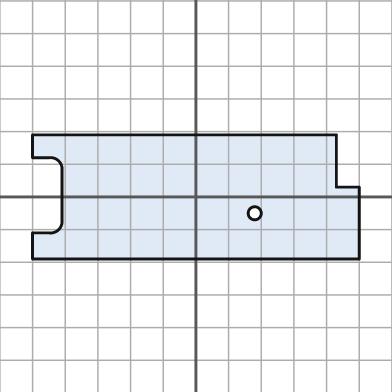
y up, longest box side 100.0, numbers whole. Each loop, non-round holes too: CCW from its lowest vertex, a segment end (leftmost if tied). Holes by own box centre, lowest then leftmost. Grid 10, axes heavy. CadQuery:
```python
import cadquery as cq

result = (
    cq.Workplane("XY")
    .moveTo(-50.0, -19.0)
    .lineTo(50.0, -19.0)
    .lineTo(50.0, 3.0)
    .lineTo(43.0, 3.0)
    .lineTo(43.0, 19.0)
    .lineTo(-50.0, 19.0)
    .lineTo(-50.0, 12.0)
    .lineTo(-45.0, 12.0)
    .threePointArc((-42.0, 11.0), (-41.0, 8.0))
    .lineTo(-41.0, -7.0)
    .threePointArc((-42.0, -10.0), (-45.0, -11.0))
    .lineTo(-50.0, -11.0)
    .close()
    .moveTo(18.0, -5.0)
    .circle(2.0)
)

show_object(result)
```